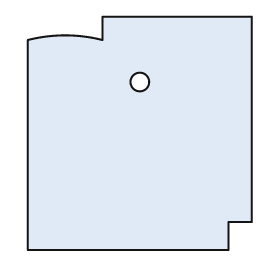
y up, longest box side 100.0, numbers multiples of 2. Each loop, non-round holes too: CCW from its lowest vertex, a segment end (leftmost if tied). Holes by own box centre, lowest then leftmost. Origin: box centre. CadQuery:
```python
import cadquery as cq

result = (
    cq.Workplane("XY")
    .moveTo(-48.0, -50.0)
    .lineTo(38.0, -50.0)
    .lineTo(38.0, -38.0)
    .lineTo(48.0, -38.0)
    .lineTo(48.0, 50.0)
    .lineTo(-16.0, 50.0)
    .lineTo(-16.0, 40.0)
    .threePointArc((-32.0, 42.0), (-48.0, 40.0))
    .close()
    .moveTo(0.0, 22.0)
    .circle(4.0)
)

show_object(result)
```